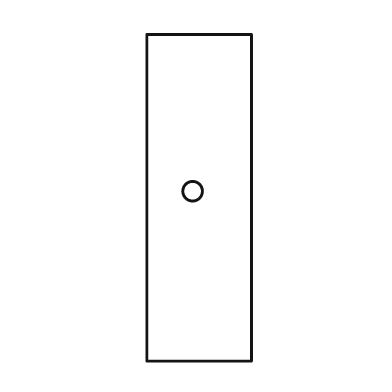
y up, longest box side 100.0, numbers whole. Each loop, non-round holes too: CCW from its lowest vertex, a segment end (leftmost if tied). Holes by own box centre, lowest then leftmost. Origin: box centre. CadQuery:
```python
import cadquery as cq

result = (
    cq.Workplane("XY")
    .moveTo(-16.0, -50.0)
    .lineTo(16.0, -50.0)
    .lineTo(16.0, 50.0)
    .lineTo(-16.0, 50.0)
    .close()
    .moveTo(-2.0, 2.0)
    .circle(3.0)
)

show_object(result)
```